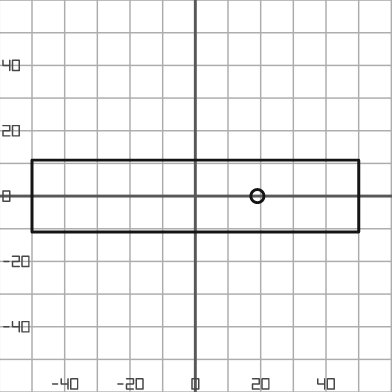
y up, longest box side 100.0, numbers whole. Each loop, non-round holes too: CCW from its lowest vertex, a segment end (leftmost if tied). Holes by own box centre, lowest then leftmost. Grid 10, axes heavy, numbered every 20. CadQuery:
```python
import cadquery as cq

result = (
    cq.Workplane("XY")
    .moveTo(-50.0, -11.0)
    .lineTo(50.0, -11.0)
    .lineTo(50.0, 11.0)
    .lineTo(-50.0, 11.0)
    .close()
    .moveTo(19.0, 0.0)
    .circle(2.0)
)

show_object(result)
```